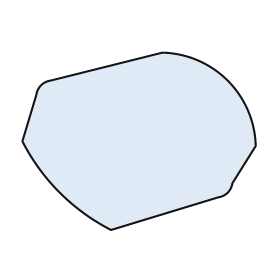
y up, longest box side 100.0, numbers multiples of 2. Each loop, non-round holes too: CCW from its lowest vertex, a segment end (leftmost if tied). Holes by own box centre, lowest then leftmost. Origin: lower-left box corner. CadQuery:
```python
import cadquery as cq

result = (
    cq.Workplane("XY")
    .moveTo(38.0, 0.0)
    .lineTo(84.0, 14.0)
    .threePointArc((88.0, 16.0), (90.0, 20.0))
    .lineTo(100.0, 36.0)
    .threePointArc((88.0, 64.0), (60.0, 76.0))
    .lineTo(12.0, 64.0)
    .threePointArc((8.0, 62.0), (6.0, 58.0))
    .lineTo(0.0, 38.0)
    .threePointArc((16.0, 16.0), (38.0, 0.0))
    .close()
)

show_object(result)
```